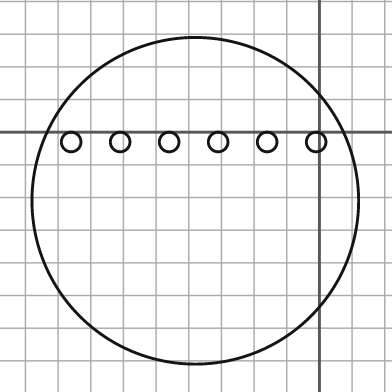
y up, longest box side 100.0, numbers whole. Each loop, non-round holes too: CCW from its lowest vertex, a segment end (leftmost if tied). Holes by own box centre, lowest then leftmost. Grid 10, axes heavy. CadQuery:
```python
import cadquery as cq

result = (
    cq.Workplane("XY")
    .moveTo(-38.0, -21.0)
    .circle(50.0)
    .moveTo(-76.0, -3.0)
    .circle(3.0)
    .moveTo(-61.0, -3.0)
    .circle(3.0)
    .moveTo(-46.0, -3.0)
    .circle(3.0)
    .moveTo(-31.0, -3.0)
    .circle(3.0)
    .moveTo(-16.0, -3.0)
    .circle(3.0)
    .moveTo(-1.0, -3.0)
    .circle(3.0)
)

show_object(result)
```